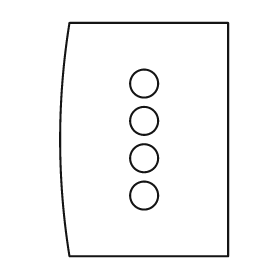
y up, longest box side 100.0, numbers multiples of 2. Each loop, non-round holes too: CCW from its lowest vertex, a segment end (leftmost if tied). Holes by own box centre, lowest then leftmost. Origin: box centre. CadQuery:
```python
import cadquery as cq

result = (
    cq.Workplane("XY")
    .moveTo(-32.0, -50.0)
    .lineTo(36.0, -50.0)
    .lineTo(36.0, 50.0)
    .lineTo(-32.0, 50.0)
    .threePointArc((-36.0, 0.0), (-32.0, -50.0))
    .close()
    .moveTo(0.0, -24.0)
    .circle(6.0)
    .moveTo(0.0, -8.0)
    .circle(6.0)
    .moveTo(0.0, 8.0)
    .circle(6.0)
    .moveTo(0.0, 24.0)
    .circle(6.0)
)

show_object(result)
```